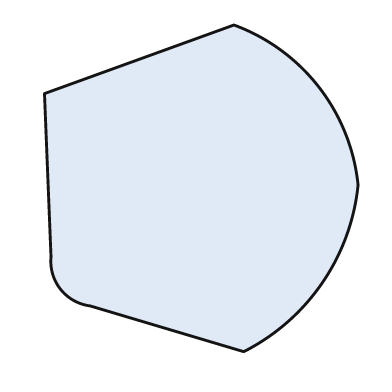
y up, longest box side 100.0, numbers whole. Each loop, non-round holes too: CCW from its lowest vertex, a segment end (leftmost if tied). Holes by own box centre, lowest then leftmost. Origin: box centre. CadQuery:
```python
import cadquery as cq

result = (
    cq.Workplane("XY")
    .moveTo(13.0, -50.0)
    .threePointArc((37.0, -29.0), (48.0, 1.0))
    .threePointArc((36.0, 31.0), (10.0, 50.0))
    .lineTo(-48.0, 29.0)
    .lineTo(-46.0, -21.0)
    .threePointArc((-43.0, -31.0), (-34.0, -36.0))
    .close()
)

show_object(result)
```